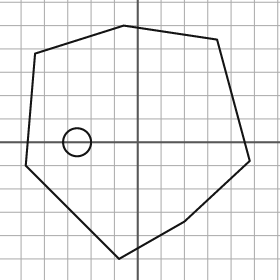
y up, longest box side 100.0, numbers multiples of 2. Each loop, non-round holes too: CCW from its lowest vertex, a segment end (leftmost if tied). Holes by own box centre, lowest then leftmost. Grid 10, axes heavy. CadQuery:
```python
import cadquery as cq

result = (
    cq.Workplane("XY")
    .moveTo(-8.0, -50.0)
    .lineTo(20.0, -34.0)
    .lineTo(48.0, -8.0)
    .lineTo(34.0, 44.0)
    .lineTo(-6.0, 50.0)
    .lineTo(-44.0, 38.0)
    .lineTo(-48.0, -10.0)
    .close()
    .moveTo(-26.0, 0.0)
    .circle(6.0)
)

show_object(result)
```